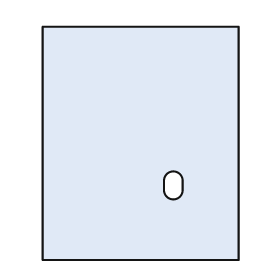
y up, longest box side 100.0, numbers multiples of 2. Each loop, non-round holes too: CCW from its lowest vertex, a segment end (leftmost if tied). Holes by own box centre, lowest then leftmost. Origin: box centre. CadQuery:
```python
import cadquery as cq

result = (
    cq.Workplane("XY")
    .moveTo(-42.0, -50.0)
    .lineTo(42.0, -50.0)
    .lineTo(42.0, 50.0)
    .lineTo(-42.0, 50.0)
    .close()
    .moveTo(10.0, -20.0)
    .threePointArc((14.0, -24.0), (18.0, -20.0))
    .lineTo(18.0, -16.0)
    .threePointArc((14.0, -12.0), (10.0, -16.0))
    .close()
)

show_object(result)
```